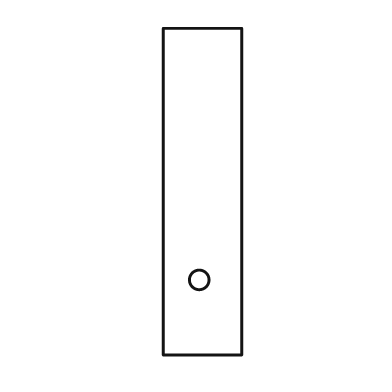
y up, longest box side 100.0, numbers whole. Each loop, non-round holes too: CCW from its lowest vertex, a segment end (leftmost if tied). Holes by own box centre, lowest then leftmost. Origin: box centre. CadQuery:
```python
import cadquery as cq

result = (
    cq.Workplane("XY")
    .moveTo(-12.0, -50.0)
    .lineTo(12.0, -50.0)
    .lineTo(12.0, 50.0)
    .lineTo(-12.0, 50.0)
    .close()
    .moveTo(-1.0, -27.0)
    .circle(3.0)
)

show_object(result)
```